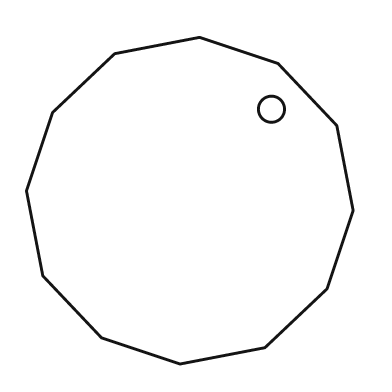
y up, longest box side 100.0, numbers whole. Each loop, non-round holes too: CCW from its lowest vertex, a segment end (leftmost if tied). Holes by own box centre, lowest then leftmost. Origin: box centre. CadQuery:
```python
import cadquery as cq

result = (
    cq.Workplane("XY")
    .moveTo(-3.0, -50.0)
    .lineTo(23.0, -45.0)
    .lineTo(42.0, -27.0)
    .lineTo(50.0, -3.0)
    .lineTo(45.0, 23.0)
    .lineTo(27.0, 42.0)
    .lineTo(3.0, 50.0)
    .lineTo(-23.0, 45.0)
    .lineTo(-42.0, 27.0)
    .lineTo(-50.0, 3.0)
    .lineTo(-45.0, -23.0)
    .lineTo(-27.0, -42.0)
    .close()
    .moveTo(25.0, 28.0)
    .circle(4.0)
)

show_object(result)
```